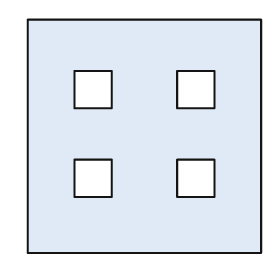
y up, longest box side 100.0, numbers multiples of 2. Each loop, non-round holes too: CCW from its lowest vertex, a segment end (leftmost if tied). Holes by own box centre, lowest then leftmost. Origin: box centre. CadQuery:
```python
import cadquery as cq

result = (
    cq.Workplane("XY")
    .moveTo(-50.0, -50.0)
    .lineTo(50.0, -50.0)
    .lineTo(50.0, 50.0)
    .lineTo(-50.0, 50.0)
    .close()
    .moveTo(-30.0, -26.0)
    .lineTo(-14.0, -26.0)
    .lineTo(-14.0, -10.0)
    .lineTo(-30.0, -10.0)
    .close()
    .moveTo(14.0, -26.0)
    .lineTo(30.0, -26.0)
    .lineTo(30.0, -10.0)
    .lineTo(14.0, -10.0)
    .close()
    .moveTo(-30.0, 12.0)
    .lineTo(-14.0, 12.0)
    .lineTo(-14.0, 28.0)
    .lineTo(-30.0, 28.0)
    .close()
    .moveTo(14.0, 12.0)
    .lineTo(30.0, 12.0)
    .lineTo(30.0, 28.0)
    .lineTo(14.0, 28.0)
    .close()
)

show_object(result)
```